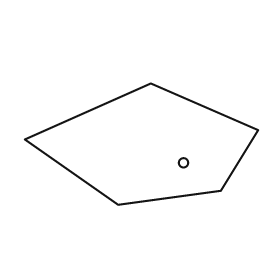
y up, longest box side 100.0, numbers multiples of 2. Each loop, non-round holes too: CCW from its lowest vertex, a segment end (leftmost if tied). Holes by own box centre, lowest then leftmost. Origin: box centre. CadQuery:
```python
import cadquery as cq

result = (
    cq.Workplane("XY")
    .moveTo(-10.0, -26.0)
    .lineTo(34.0, -20.0)
    .lineTo(50.0, 6.0)
    .lineTo(4.0, 26.0)
    .lineTo(-50.0, 2.0)
    .close()
    .moveTo(18.0, -8.0)
    .circle(2.0)
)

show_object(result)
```